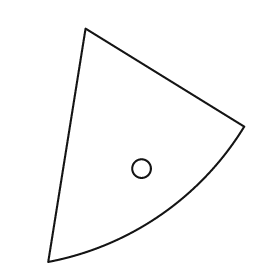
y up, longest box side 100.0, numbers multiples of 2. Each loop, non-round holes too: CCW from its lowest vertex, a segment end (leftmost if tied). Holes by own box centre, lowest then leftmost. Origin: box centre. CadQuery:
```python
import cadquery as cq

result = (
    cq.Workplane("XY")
    .moveTo(-42.0, -50.0)
    .threePointArc((6.0, -30.0), (42.0, 8.0))
    .lineTo(-26.0, 50.0)
    .close()
    .moveTo(-2.0, -10.0)
    .circle(4.0)
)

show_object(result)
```